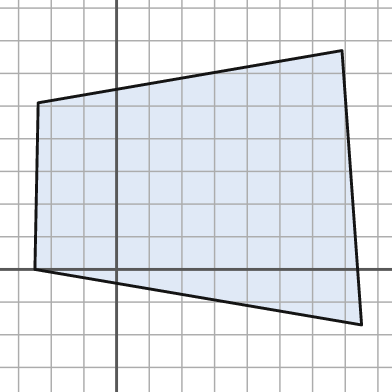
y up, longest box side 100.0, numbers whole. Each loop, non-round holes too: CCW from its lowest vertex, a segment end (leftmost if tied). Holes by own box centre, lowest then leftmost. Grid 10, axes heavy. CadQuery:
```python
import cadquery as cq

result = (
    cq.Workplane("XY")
    .moveTo(75.0, -17.0)
    .lineTo(69.0, 67.0)
    .lineTo(-24.0, 51.0)
    .lineTo(-25.0, 0.0)
    .close()
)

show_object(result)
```